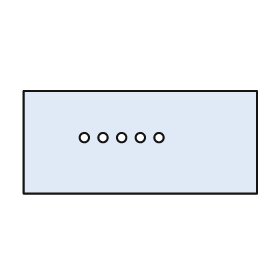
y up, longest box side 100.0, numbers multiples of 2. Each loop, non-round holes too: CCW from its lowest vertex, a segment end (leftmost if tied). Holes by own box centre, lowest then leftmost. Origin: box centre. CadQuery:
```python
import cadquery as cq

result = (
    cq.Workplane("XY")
    .moveTo(-50.0, -22.0)
    .lineTo(50.0, -22.0)
    .lineTo(50.0, 22.0)
    .lineTo(-50.0, 22.0)
    .close()
    .moveTo(-24.0, 2.0)
    .circle(2.0)
    .moveTo(-16.0, 2.0)
    .circle(2.0)
    .moveTo(-8.0, 2.0)
    .circle(2.0)
    .moveTo(0.0, 2.0)
    .circle(2.0)
    .moveTo(8.0, 2.0)
    .circle(2.0)
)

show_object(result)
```